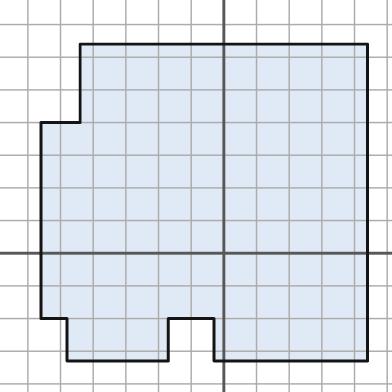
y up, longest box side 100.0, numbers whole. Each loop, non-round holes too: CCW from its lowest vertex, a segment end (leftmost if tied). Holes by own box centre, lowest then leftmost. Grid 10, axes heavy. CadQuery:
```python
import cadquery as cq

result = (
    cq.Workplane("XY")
    .moveTo(-48.0, -33.0)
    .lineTo(-17.0, -33.0)
    .lineTo(-17.0, -20.0)
    .lineTo(-3.0, -20.0)
    .lineTo(-3.0, -33.0)
    .lineTo(44.0, -33.0)
    .lineTo(44.0, 64.0)
    .lineTo(-44.0, 64.0)
    .lineTo(-44.0, 40.0)
    .lineTo(-56.0, 40.0)
    .lineTo(-56.0, -20.0)
    .lineTo(-48.0, -20.0)
    .close()
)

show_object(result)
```